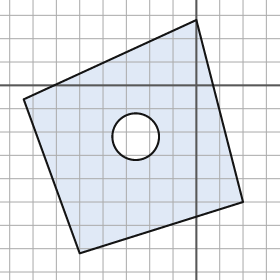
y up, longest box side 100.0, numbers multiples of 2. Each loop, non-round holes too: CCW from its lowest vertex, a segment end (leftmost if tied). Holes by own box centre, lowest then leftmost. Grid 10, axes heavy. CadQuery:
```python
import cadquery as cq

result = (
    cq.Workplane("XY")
    .moveTo(-50.0, -72.0)
    .lineTo(20.0, -50.0)
    .lineTo(0.0, 28.0)
    .lineTo(-74.0, -6.0)
    .close()
    .moveTo(-26.0, -22.0)
    .circle(10.0)
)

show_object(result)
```